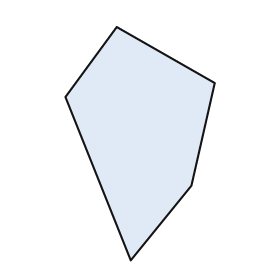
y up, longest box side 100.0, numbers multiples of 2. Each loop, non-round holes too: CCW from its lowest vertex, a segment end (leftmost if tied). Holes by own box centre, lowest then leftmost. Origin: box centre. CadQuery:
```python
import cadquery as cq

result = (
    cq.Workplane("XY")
    .moveTo(-4.0, -50.0)
    .lineTo(22.0, -18.0)
    .lineTo(32.0, 26.0)
    .lineTo(-10.0, 50.0)
    .lineTo(-32.0, 20.0)
    .close()
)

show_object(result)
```